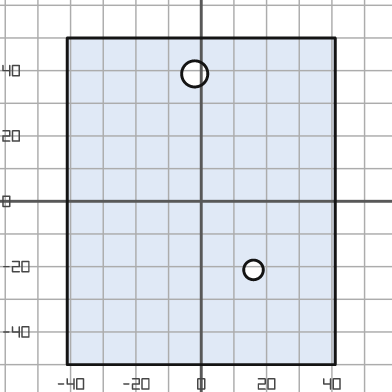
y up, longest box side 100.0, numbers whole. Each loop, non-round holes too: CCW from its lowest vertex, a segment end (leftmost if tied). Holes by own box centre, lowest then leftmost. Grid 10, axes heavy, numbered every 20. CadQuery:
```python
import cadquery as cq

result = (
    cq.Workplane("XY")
    .moveTo(-41.0, -50.0)
    .lineTo(41.0, -50.0)
    .lineTo(41.0, 50.0)
    .lineTo(-41.0, 50.0)
    .close()
    .moveTo(16.0, -21.0)
    .circle(3.0)
    .moveTo(-2.0, 39.0)
    .circle(4.0)
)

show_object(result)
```